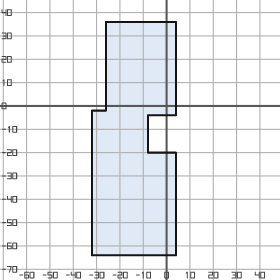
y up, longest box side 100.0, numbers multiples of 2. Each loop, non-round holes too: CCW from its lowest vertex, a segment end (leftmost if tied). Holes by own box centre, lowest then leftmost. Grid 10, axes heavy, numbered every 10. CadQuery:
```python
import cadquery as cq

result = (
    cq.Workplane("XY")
    .moveTo(-32.0, -64.0)
    .lineTo(4.0, -64.0)
    .lineTo(4.0, -20.0)
    .lineTo(-8.0, -20.0)
    .lineTo(-8.0, -4.0)
    .lineTo(4.0, -4.0)
    .lineTo(4.0, 36.0)
    .lineTo(-26.0, 36.0)
    .lineTo(-26.0, -2.0)
    .lineTo(-32.0, -2.0)
    .close()
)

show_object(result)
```